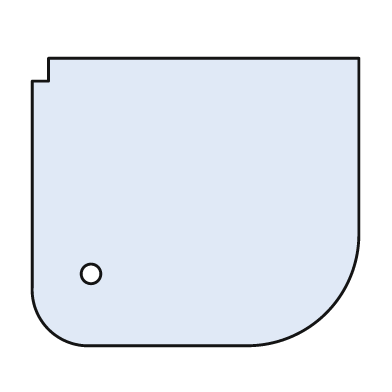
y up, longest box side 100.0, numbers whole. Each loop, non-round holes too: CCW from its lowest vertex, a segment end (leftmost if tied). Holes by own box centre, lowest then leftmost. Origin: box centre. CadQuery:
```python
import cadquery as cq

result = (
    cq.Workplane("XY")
    .moveTo(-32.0, -44.0)
    .lineTo(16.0, -44.0)
    .threePointArc((40.0, -34.0), (50.0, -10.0))
    .lineTo(50.0, 44.0)
    .lineTo(-45.0, 44.0)
    .lineTo(-45.0, 37.0)
    .lineTo(-50.0, 37.0)
    .lineTo(-50.0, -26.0)
    .threePointArc((-45.0, -39.0), (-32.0, -44.0))
    .close()
    .moveTo(-32.0, -22.0)
    .circle(3.0)
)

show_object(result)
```